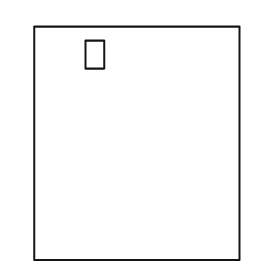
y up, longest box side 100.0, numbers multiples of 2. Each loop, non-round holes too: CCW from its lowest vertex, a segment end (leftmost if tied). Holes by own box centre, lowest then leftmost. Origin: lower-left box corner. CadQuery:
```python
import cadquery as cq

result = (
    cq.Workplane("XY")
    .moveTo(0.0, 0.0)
    .lineTo(88.0, 0.0)
    .lineTo(88.0, 100.0)
    .lineTo(0.0, 100.0)
    .close()
    .moveTo(22.0, 82.0)
    .lineTo(30.0, 82.0)
    .lineTo(30.0, 94.0)
    .lineTo(22.0, 94.0)
    .close()
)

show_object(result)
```